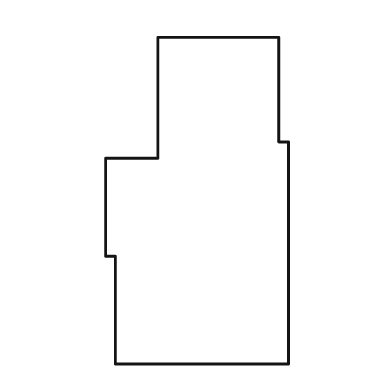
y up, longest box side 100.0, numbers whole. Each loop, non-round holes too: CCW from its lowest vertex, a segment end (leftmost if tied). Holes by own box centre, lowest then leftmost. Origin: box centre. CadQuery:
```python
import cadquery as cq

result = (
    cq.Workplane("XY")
    .moveTo(-25.0, -50.0)
    .lineTo(28.0, -50.0)
    .lineTo(28.0, 18.0)
    .lineTo(25.0, 18.0)
    .lineTo(25.0, 50.0)
    .lineTo(-12.0, 50.0)
    .lineTo(-12.0, 13.0)
    .lineTo(-28.0, 13.0)
    .lineTo(-28.0, -17.0)
    .lineTo(-25.0, -17.0)
    .close()
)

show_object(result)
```